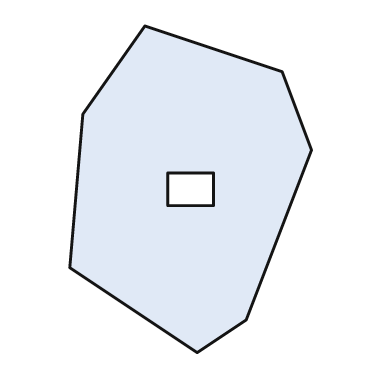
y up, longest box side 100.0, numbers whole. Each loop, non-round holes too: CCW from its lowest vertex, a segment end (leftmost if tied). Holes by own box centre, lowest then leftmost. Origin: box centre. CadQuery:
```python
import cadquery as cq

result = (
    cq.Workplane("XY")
    .moveTo(2.0, -50.0)
    .lineTo(17.0, -40.0)
    .lineTo(37.0, 12.0)
    .lineTo(28.0, 36.0)
    .lineTo(-14.0, 50.0)
    .lineTo(-33.0, 23.0)
    .lineTo(-37.0, -24.0)
    .close()
    .moveTo(-7.0, -5.0)
    .lineTo(7.0, -5.0)
    .lineTo(7.0, 5.0)
    .lineTo(-7.0, 5.0)
    .close()
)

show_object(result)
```